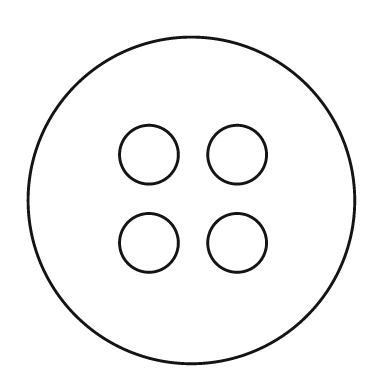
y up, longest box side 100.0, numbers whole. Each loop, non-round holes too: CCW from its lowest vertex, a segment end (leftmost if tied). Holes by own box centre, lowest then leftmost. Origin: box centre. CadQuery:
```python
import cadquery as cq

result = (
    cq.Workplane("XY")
    .moveTo(0.0, 0.0)
    .circle(50.0)
    .moveTo(-13.0, -13.0)
    .circle(9.0)
    .moveTo(14.0, -13.0)
    .circle(9.0)
    .moveTo(-13.0, 14.0)
    .circle(9.0)
    .moveTo(14.0, 14.0)
    .circle(9.0)
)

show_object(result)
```